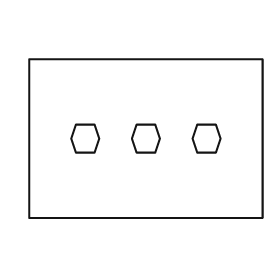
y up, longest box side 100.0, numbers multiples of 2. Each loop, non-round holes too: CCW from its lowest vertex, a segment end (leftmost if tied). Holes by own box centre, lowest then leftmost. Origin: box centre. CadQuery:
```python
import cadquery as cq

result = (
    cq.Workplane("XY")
    .moveTo(-50.0, -34.0)
    .lineTo(50.0, -34.0)
    .lineTo(50.0, 34.0)
    .lineTo(-50.0, 34.0)
    .close()
    .moveTo(-30.0, -6.0)
    .lineTo(-22.0, -6.0)
    .lineTo(-20.0, 0.0)
    .lineTo(-22.0, 6.0)
    .lineTo(-30.0, 6.0)
    .lineTo(-32.0, 0.0)
    .close()
    .moveTo(-4.0, -6.0)
    .lineTo(4.0, -6.0)
    .lineTo(6.0, 0.0)
    .lineTo(4.0, 6.0)
    .lineTo(-4.0, 6.0)
    .lineTo(-6.0, 0.0)
    .close()
    .moveTo(22.0, -6.0)
    .lineTo(30.0, -6.0)
    .lineTo(32.0, 0.0)
    .lineTo(30.0, 6.0)
    .lineTo(22.0, 6.0)
    .lineTo(20.0, 0.0)
    .close()
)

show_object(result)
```